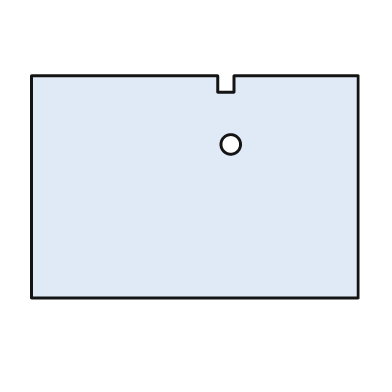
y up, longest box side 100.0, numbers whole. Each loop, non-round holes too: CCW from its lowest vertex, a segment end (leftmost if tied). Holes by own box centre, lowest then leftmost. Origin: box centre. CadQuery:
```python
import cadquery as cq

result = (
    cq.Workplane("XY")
    .moveTo(-50.0, -34.0)
    .lineTo(50.0, -34.0)
    .lineTo(50.0, 34.0)
    .lineTo(12.0, 34.0)
    .lineTo(12.0, 29.0)
    .lineTo(7.0, 29.0)
    .lineTo(7.0, 34.0)
    .lineTo(-50.0, 34.0)
    .close()
    .moveTo(11.0, 13.0)
    .circle(3.0)
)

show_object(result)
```